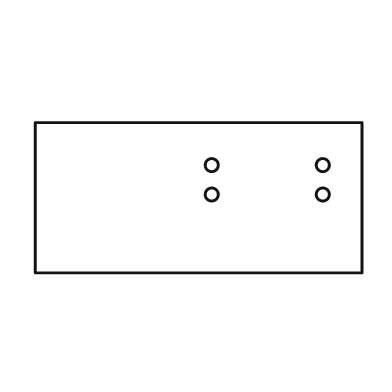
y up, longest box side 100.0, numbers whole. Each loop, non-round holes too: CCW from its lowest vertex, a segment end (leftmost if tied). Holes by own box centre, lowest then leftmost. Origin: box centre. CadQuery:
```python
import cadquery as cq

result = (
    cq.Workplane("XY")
    .moveTo(-50.0, -23.0)
    .lineTo(50.0, -23.0)
    .lineTo(50.0, 23.0)
    .lineTo(-50.0, 23.0)
    .close()
    .moveTo(4.0, 1.0)
    .circle(2.0)
    .moveTo(38.0, 1.0)
    .circle(2.0)
    .moveTo(4.0, 10.0)
    .circle(2.0)
    .moveTo(38.0, 10.0)
    .circle(2.0)
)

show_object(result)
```